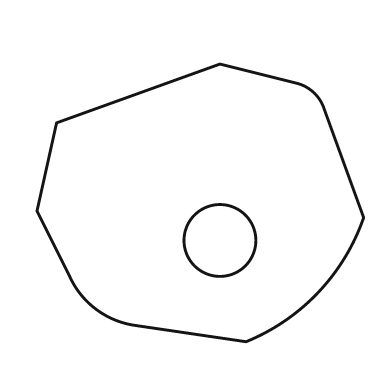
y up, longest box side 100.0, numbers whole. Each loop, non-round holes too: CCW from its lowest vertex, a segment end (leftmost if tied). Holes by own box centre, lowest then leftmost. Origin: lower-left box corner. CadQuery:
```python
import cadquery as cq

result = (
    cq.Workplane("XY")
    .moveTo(64.0, 0.0)
    .threePointArc((86.0, 15.0), (100.0, 38.0))
    .lineTo(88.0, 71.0)
    .threePointArc((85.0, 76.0), (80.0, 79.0))
    .lineTo(56.0, 85.0)
    .lineTo(6.0, 67.0)
    .lineTo(0.0, 40.0)
    .lineTo(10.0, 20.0)
    .threePointArc((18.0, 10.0), (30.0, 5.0))
    .close()
    .moveTo(56.0, 31.0)
    .circle(11.0)
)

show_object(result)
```